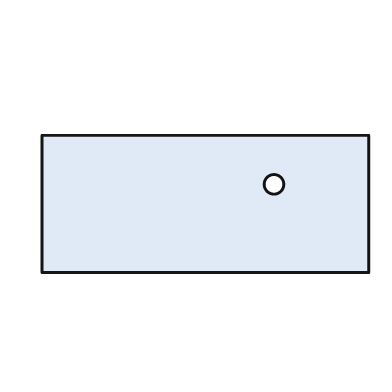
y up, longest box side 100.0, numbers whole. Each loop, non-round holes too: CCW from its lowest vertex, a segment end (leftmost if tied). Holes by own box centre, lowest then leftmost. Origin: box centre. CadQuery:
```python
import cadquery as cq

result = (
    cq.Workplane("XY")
    .moveTo(-50.0, -21.0)
    .lineTo(50.0, -21.0)
    .lineTo(50.0, 21.0)
    .lineTo(-50.0, 21.0)
    .close()
    .moveTo(21.0, 6.0)
    .circle(3.0)
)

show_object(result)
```